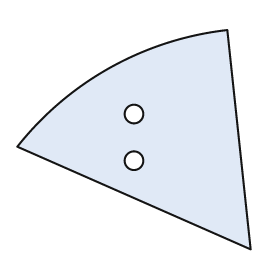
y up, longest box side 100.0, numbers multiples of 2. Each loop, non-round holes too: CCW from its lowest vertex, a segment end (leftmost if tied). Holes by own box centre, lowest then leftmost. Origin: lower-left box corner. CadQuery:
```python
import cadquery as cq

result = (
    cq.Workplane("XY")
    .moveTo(100.0, 0.0)
    .lineTo(90.0, 94.0)
    .threePointArc((40.0, 78.0), (0.0, 44.0))
    .close()
    .moveTo(50.0, 38.0)
    .circle(4.0)
    .moveTo(50.0, 58.0)
    .circle(4.0)
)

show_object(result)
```